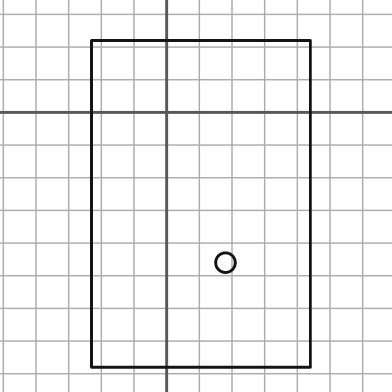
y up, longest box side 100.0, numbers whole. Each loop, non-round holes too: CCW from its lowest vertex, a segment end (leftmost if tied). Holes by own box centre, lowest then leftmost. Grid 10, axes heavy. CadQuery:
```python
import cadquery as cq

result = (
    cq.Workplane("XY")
    .moveTo(-23.0, -78.0)
    .lineTo(44.0, -78.0)
    .lineTo(44.0, 22.0)
    .lineTo(-23.0, 22.0)
    .close()
    .moveTo(18.0, -46.0)
    .circle(3.0)
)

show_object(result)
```